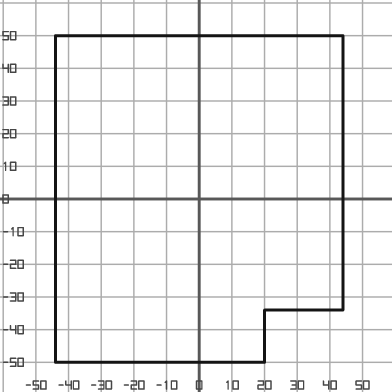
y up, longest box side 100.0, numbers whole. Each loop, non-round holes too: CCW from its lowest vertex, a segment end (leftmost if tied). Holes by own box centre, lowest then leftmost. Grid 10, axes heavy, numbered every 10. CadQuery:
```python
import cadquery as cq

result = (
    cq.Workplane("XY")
    .moveTo(-44.0, -50.0)
    .lineTo(20.0, -50.0)
    .lineTo(20.0, -34.0)
    .lineTo(44.0, -34.0)
    .lineTo(44.0, 50.0)
    .lineTo(-44.0, 50.0)
    .close()
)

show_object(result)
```